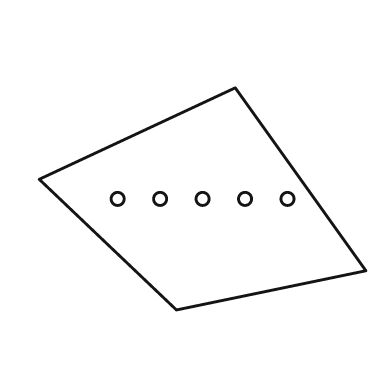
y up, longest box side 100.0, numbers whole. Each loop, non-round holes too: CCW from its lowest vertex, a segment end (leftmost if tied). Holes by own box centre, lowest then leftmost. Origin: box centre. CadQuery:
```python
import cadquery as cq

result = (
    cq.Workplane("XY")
    .moveTo(-8.0, -34.0)
    .lineTo(50.0, -22.0)
    .lineTo(10.0, 34.0)
    .lineTo(-50.0, 6.0)
    .close()
    .moveTo(-26.0, 0.0)
    .circle(2.0)
    .moveTo(-13.0, 0.0)
    .circle(2.0)
    .moveTo(0.0, 0.0)
    .circle(2.0)
    .moveTo(13.0, 0.0)
    .circle(2.0)
    .moveTo(26.0, 0.0)
    .circle(2.0)
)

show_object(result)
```